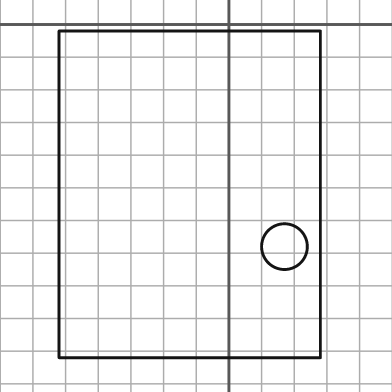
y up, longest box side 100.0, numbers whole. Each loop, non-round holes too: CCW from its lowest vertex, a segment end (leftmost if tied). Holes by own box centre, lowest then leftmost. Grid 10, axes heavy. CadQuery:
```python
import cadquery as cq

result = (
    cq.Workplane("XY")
    .moveTo(-52.0, -102.0)
    .lineTo(28.0, -102.0)
    .lineTo(28.0, -2.0)
    .lineTo(-52.0, -2.0)
    .close()
    .moveTo(17.0, -68.0)
    .circle(7.0)
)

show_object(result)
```